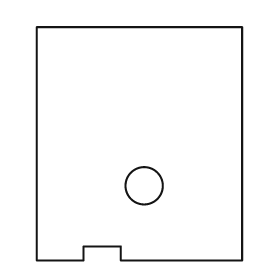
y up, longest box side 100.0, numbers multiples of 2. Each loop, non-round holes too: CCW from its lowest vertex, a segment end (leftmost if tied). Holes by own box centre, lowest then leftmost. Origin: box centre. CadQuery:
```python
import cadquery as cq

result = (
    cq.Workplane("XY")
    .moveTo(-44.0, -50.0)
    .lineTo(-24.0, -50.0)
    .lineTo(-24.0, -44.0)
    .lineTo(-8.0, -44.0)
    .lineTo(-8.0, -50.0)
    .lineTo(44.0, -50.0)
    .lineTo(44.0, 50.0)
    .lineTo(-44.0, 50.0)
    .close()
    .moveTo(2.0, -18.0)
    .circle(8.0)
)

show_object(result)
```